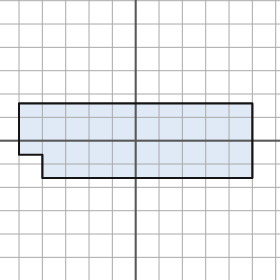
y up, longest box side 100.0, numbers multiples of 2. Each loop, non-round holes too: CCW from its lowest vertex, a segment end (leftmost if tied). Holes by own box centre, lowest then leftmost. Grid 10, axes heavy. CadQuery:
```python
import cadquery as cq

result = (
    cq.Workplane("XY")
    .moveTo(-40.0, -16.0)
    .lineTo(50.0, -16.0)
    .lineTo(50.0, 16.0)
    .lineTo(-50.0, 16.0)
    .lineTo(-50.0, -6.0)
    .lineTo(-40.0, -6.0)
    .close()
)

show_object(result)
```